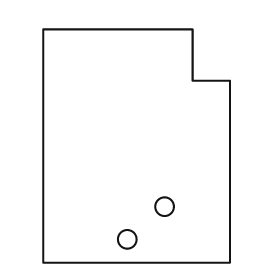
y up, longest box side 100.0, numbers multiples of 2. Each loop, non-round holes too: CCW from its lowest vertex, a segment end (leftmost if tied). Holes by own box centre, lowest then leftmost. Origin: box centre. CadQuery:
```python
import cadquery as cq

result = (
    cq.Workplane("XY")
    .moveTo(-40.0, -50.0)
    .lineTo(40.0, -50.0)
    .lineTo(40.0, 28.0)
    .lineTo(24.0, 28.0)
    .lineTo(24.0, 50.0)
    .lineTo(-40.0, 50.0)
    .close()
    .moveTo(-4.0, -40.0)
    .circle(4.0)
    .moveTo(12.0, -26.0)
    .circle(4.0)
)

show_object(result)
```